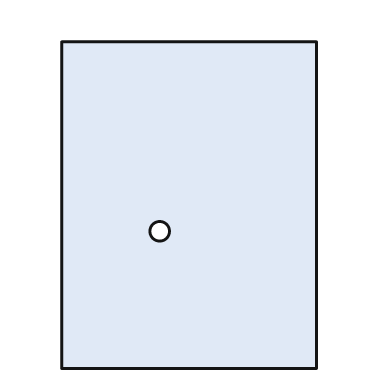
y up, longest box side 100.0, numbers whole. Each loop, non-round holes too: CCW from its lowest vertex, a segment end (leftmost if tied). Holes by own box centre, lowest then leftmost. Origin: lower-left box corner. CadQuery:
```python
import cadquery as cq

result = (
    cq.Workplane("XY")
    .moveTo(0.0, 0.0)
    .lineTo(78.0, 0.0)
    .lineTo(78.0, 100.0)
    .lineTo(0.0, 100.0)
    .close()
    .moveTo(30.0, 42.0)
    .circle(3.0)
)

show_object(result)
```